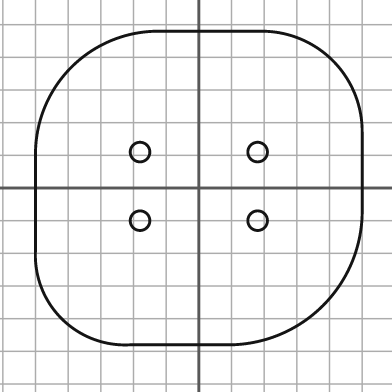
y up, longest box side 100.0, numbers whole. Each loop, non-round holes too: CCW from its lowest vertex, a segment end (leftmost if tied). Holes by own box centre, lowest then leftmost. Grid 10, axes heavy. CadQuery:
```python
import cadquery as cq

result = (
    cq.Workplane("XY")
    .moveTo(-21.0, -48.0)
    .lineTo(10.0, -48.0)
    .threePointArc((38.0, -36.0), (50.0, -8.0))
    .lineTo(50.0, 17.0)
    .threePointArc((41.0, 39.0), (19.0, 48.0))
    .lineTo(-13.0, 48.0)
    .threePointArc((-39.0, 37.0), (-50.0, 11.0))
    .lineTo(-50.0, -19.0)
    .threePointArc((-42.0, -40.0), (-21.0, -48.0))
    .close()
    .moveTo(-18.0, -10.0)
    .circle(3.0)
    .moveTo(18.0, -10.0)
    .circle(3.0)
    .moveTo(-18.0, 11.0)
    .circle(3.0)
    .moveTo(18.0, 11.0)
    .circle(3.0)
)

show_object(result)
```